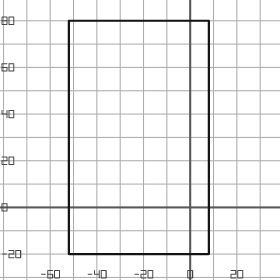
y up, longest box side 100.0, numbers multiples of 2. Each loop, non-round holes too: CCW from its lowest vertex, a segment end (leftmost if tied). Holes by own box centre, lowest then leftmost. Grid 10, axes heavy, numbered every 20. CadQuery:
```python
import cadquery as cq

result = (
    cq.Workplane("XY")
    .moveTo(-52.0, -20.0)
    .lineTo(8.0, -20.0)
    .lineTo(8.0, 80.0)
    .lineTo(-52.0, 80.0)
    .close()
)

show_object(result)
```